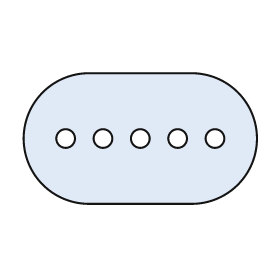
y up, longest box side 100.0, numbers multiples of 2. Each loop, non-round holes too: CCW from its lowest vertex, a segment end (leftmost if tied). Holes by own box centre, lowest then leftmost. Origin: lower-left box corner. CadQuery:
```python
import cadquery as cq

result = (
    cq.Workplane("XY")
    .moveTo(28.0, 0.0)
    .lineTo(72.0, 0.0)
    .threePointArc((100.0, 28.0), (72.0, 56.0))
    .lineTo(28.0, 56.0)
    .threePointArc((0.0, 28.0), (28.0, 0.0))
    .close()
    .moveTo(18.0, 28.0)
    .circle(4.0)
    .moveTo(34.0, 28.0)
    .circle(4.0)
    .moveTo(50.0, 28.0)
    .circle(4.0)
    .moveTo(66.0, 28.0)
    .circle(4.0)
    .moveTo(82.0, 28.0)
    .circle(4.0)
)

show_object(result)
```